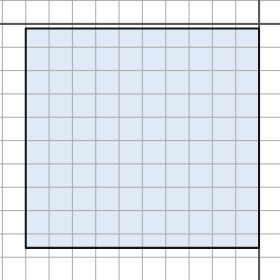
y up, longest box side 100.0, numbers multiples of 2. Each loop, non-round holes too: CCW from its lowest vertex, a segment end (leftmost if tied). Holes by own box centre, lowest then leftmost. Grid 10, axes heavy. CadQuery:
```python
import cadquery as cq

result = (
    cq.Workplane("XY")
    .moveTo(-100.0, -96.0)
    .lineTo(0.0, -96.0)
    .lineTo(0.0, -2.0)
    .lineTo(-100.0, -2.0)
    .close()
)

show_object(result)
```